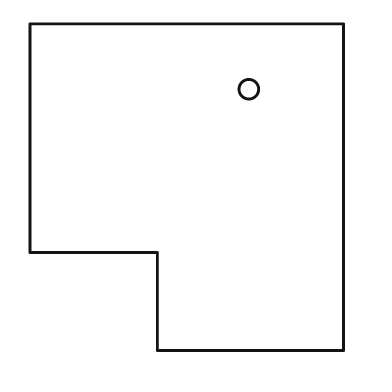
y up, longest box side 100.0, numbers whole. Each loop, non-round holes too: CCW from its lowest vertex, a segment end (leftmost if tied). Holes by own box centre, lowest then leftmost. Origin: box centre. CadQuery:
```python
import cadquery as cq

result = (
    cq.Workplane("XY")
    .moveTo(-9.0, -50.0)
    .lineTo(48.0, -50.0)
    .lineTo(48.0, 50.0)
    .lineTo(-48.0, 50.0)
    .lineTo(-48.0, -20.0)
    .lineTo(-9.0, -20.0)
    .close()
    .moveTo(19.0, 30.0)
    .circle(3.0)
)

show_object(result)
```